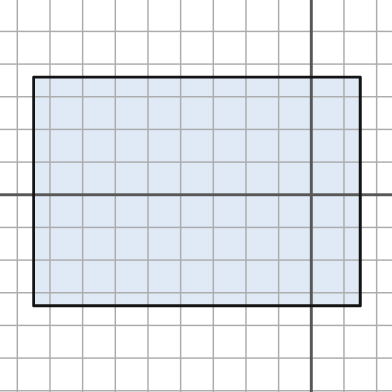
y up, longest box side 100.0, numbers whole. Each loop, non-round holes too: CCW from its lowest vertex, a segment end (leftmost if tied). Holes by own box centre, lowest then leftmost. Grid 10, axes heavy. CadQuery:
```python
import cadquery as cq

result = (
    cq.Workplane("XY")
    .moveTo(-85.0, -34.0)
    .lineTo(15.0, -34.0)
    .lineTo(15.0, 36.0)
    .lineTo(-85.0, 36.0)
    .close()
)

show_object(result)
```